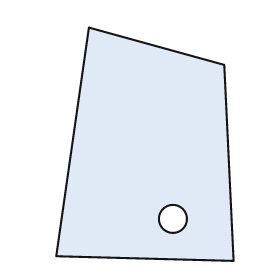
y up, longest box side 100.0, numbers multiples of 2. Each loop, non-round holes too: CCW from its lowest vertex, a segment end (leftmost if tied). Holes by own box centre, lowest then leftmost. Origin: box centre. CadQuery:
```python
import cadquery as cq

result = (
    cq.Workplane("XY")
    .moveTo(38.0, -50.0)
    .lineTo(34.0, 34.0)
    .lineTo(-24.0, 50.0)
    .lineTo(-38.0, -48.0)
    .close()
    .moveTo(12.0, -32.0)
    .circle(6.0)
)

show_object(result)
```